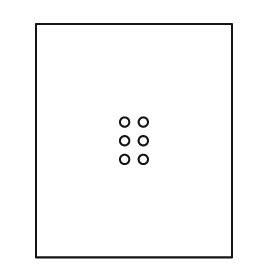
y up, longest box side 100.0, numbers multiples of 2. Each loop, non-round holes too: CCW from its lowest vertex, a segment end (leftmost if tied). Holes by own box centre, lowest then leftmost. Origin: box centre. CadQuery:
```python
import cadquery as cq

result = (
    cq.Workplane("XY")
    .moveTo(-42.0, -50.0)
    .lineTo(42.0, -50.0)
    .lineTo(42.0, 50.0)
    .lineTo(-42.0, 50.0)
    .close()
    .moveTo(-4.0, -8.0)
    .circle(2.0)
    .moveTo(4.0, -8.0)
    .circle(2.0)
    .moveTo(-4.0, 0.0)
    .circle(2.0)
    .moveTo(4.0, 0.0)
    .circle(2.0)
    .moveTo(-4.0, 8.0)
    .circle(2.0)
    .moveTo(4.0, 8.0)
    .circle(2.0)
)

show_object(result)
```